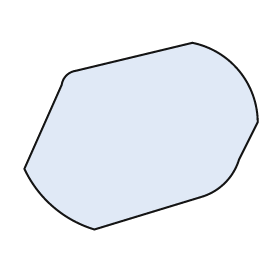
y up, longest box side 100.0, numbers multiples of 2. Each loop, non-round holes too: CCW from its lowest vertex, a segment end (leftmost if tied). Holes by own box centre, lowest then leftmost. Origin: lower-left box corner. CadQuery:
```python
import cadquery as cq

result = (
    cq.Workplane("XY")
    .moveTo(30.0, 0.0)
    .lineTo(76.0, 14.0)
    .threePointArc((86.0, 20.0), (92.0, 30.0))
    .lineTo(100.0, 46.0)
    .threePointArc((92.0, 68.0), (72.0, 80.0))
    .lineTo(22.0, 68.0)
    .threePointArc((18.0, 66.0), (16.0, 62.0))
    .lineTo(0.0, 26.0)
    .threePointArc((12.0, 10.0), (30.0, 0.0))
    .close()
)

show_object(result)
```